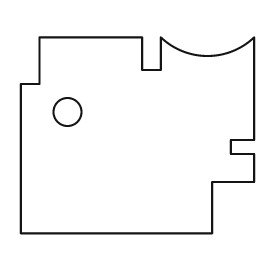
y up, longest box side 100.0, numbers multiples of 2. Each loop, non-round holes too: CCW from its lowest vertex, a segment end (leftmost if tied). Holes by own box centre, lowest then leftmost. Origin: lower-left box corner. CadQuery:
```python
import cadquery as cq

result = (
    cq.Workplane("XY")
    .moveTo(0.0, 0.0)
    .lineTo(82.0, 0.0)
    .lineTo(82.0, 22.0)
    .lineTo(100.0, 22.0)
    .lineTo(100.0, 34.0)
    .lineTo(90.0, 34.0)
    .lineTo(90.0, 40.0)
    .lineTo(100.0, 40.0)
    .lineTo(100.0, 84.0)
    .threePointArc((80.0, 76.0), (60.0, 84.0))
    .lineTo(60.0, 70.0)
    .lineTo(52.0, 70.0)
    .lineTo(52.0, 84.0)
    .lineTo(8.0, 84.0)
    .lineTo(8.0, 64.0)
    .lineTo(0.0, 64.0)
    .close()
    .moveTo(20.0, 52.0)
    .circle(6.0)
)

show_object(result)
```